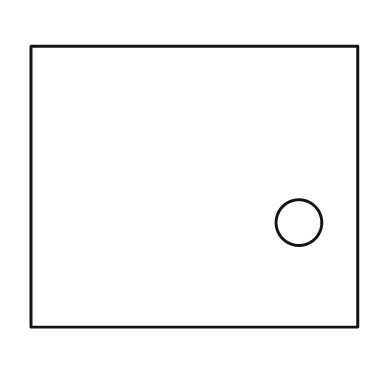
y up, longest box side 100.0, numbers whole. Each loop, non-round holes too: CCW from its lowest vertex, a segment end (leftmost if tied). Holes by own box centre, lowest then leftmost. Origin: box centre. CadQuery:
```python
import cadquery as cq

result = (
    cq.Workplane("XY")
    .moveTo(-50.0, -43.0)
    .lineTo(50.0, -43.0)
    .lineTo(50.0, 43.0)
    .lineTo(-50.0, 43.0)
    .close()
    .moveTo(32.0, -11.0)
    .circle(7.0)
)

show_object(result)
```